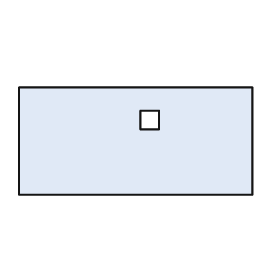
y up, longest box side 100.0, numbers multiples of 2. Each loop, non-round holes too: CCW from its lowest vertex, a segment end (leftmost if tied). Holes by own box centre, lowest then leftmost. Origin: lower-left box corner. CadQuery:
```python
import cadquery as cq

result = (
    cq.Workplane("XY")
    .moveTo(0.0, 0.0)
    .lineTo(100.0, 0.0)
    .lineTo(100.0, 46.0)
    .lineTo(0.0, 46.0)
    .close()
    .moveTo(52.0, 28.0)
    .lineTo(60.0, 28.0)
    .lineTo(60.0, 36.0)
    .lineTo(52.0, 36.0)
    .close()
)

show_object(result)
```